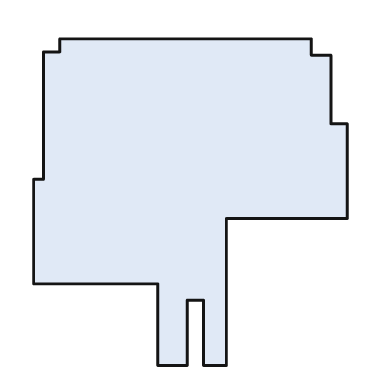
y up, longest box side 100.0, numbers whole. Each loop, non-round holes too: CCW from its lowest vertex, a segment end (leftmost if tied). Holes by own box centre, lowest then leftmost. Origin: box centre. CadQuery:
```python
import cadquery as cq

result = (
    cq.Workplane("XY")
    .moveTo(-10.0, -50.0)
    .lineTo(-1.0, -50.0)
    .lineTo(-1.0, -30.0)
    .lineTo(4.0, -30.0)
    .lineTo(4.0, -50.0)
    .lineTo(11.0, -50.0)
    .lineTo(11.0, -5.0)
    .lineTo(48.0, -5.0)
    .lineTo(48.0, 24.0)
    .lineTo(43.0, 24.0)
    .lineTo(43.0, 45.0)
    .lineTo(37.0, 45.0)
    .lineTo(37.0, 50.0)
    .lineTo(-40.0, 50.0)
    .lineTo(-40.0, 46.0)
    .lineTo(-45.0, 46.0)
    .lineTo(-45.0, 7.0)
    .lineTo(-48.0, 7.0)
    .lineTo(-48.0, -25.0)
    .lineTo(-10.0, -25.0)
    .close()
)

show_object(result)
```